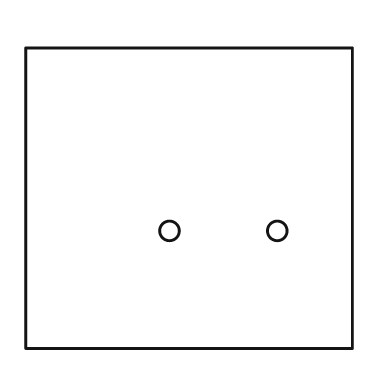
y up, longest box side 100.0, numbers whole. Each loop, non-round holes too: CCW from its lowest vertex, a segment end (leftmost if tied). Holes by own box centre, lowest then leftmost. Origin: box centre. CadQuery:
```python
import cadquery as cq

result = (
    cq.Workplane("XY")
    .moveTo(-50.0, -46.0)
    .lineTo(50.0, -46.0)
    .lineTo(50.0, 46.0)
    .lineTo(-50.0, 46.0)
    .close()
    .moveTo(-6.0, -10.0)
    .circle(3.0)
    .moveTo(27.0, -10.0)
    .circle(3.0)
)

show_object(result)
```